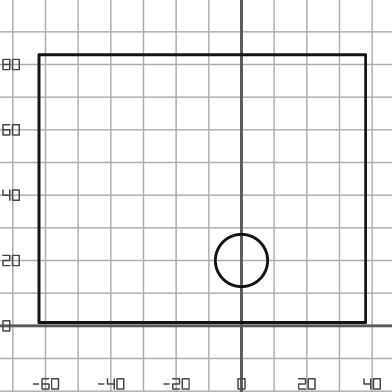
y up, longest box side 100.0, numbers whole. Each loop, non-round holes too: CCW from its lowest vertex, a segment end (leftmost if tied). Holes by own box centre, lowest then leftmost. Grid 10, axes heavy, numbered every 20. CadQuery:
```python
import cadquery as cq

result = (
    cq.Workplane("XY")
    .moveTo(-62.0, 1.0)
    .lineTo(38.0, 1.0)
    .lineTo(38.0, 83.0)
    .lineTo(-62.0, 83.0)
    .close()
    .moveTo(0.0, 20.0)
    .circle(8.0)
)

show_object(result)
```